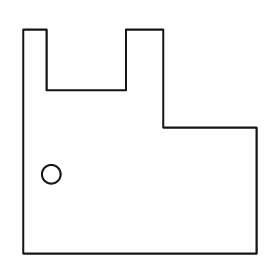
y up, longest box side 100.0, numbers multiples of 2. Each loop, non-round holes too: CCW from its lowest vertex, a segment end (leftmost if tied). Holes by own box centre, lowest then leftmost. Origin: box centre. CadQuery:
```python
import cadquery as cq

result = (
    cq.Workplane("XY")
    .moveTo(-50.0, -48.0)
    .lineTo(50.0, -48.0)
    .lineTo(50.0, 6.0)
    .lineTo(10.0, 6.0)
    .lineTo(10.0, 48.0)
    .lineTo(-6.0, 48.0)
    .lineTo(-6.0, 22.0)
    .lineTo(-40.0, 22.0)
    .lineTo(-40.0, 48.0)
    .lineTo(-50.0, 48.0)
    .close()
    .moveTo(-38.0, -14.0)
    .circle(4.0)
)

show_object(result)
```